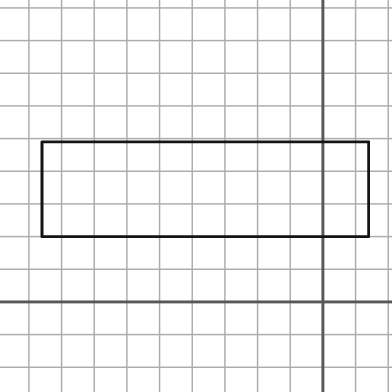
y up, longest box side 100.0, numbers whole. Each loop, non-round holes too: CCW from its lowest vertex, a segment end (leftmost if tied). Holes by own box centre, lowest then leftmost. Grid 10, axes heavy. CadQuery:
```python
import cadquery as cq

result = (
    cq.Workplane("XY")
    .moveTo(-86.0, 20.0)
    .lineTo(14.0, 20.0)
    .lineTo(14.0, 49.0)
    .lineTo(-86.0, 49.0)
    .close()
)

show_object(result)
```